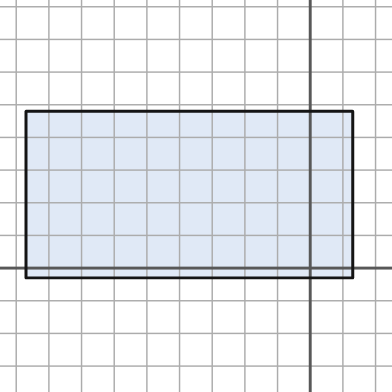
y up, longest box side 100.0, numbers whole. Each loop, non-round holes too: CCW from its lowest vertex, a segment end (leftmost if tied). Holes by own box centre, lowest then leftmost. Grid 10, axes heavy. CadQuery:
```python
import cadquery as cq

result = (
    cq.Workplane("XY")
    .moveTo(-87.0, -3.0)
    .lineTo(13.0, -3.0)
    .lineTo(13.0, 48.0)
    .lineTo(-87.0, 48.0)
    .close()
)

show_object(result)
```